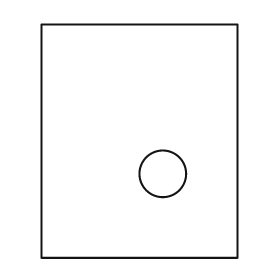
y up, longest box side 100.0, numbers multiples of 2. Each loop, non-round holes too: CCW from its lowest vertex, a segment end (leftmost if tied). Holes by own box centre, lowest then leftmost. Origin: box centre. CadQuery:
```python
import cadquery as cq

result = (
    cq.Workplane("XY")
    .moveTo(-42.0, -50.0)
    .lineTo(42.0, -50.0)
    .lineTo(42.0, 50.0)
    .lineTo(-42.0, 50.0)
    .close()
    .moveTo(10.0, -14.0)
    .circle(10.0)
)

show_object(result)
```